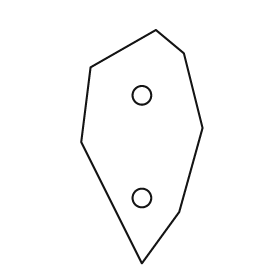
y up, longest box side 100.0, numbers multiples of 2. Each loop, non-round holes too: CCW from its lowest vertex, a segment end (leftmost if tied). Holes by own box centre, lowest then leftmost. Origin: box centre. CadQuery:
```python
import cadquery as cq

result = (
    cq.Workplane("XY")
    .moveTo(0.0, -50.0)
    .lineTo(16.0, -28.0)
    .lineTo(26.0, 8.0)
    .lineTo(18.0, 40.0)
    .lineTo(6.0, 50.0)
    .lineTo(-22.0, 34.0)
    .lineTo(-26.0, 2.0)
    .close()
    .moveTo(0.0, -22.0)
    .circle(4.0)
    .moveTo(0.0, 22.0)
    .circle(4.0)
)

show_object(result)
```